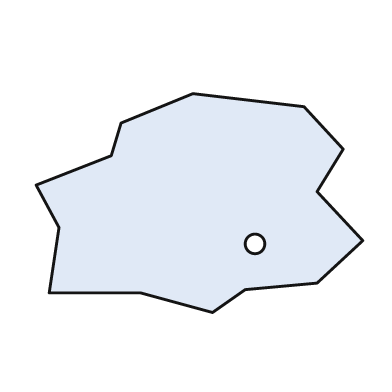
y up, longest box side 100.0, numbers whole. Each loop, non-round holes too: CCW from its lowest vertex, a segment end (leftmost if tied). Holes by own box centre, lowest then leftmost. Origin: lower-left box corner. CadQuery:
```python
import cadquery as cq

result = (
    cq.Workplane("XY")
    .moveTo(54.0, 0.0)
    .lineTo(64.0, 7.0)
    .lineTo(86.0, 9.0)
    .lineTo(100.0, 22.0)
    .lineTo(86.0, 37.0)
    .lineTo(94.0, 50.0)
    .lineTo(82.0, 63.0)
    .lineTo(48.0, 67.0)
    .lineTo(26.0, 58.0)
    .lineTo(23.0, 48.0)
    .lineTo(0.0, 39.0)
    .lineTo(7.0, 26.0)
    .lineTo(4.0, 6.0)
    .lineTo(32.0, 6.0)
    .close()
    .moveTo(67.0, 21.0)
    .circle(3.0)
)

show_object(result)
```